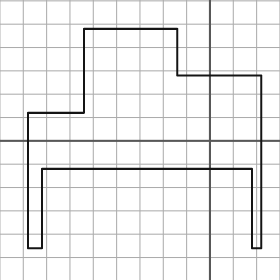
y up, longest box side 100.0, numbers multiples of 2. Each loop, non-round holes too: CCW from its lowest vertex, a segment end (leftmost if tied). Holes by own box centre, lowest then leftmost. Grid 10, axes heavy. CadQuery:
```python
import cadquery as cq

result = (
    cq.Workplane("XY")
    .moveTo(-78.0, -46.0)
    .lineTo(-72.0, -46.0)
    .lineTo(-72.0, -12.0)
    .lineTo(18.0, -12.0)
    .lineTo(18.0, -46.0)
    .lineTo(22.0, -46.0)
    .lineTo(22.0, 28.0)
    .lineTo(-14.0, 28.0)
    .lineTo(-14.0, 48.0)
    .lineTo(-54.0, 48.0)
    .lineTo(-54.0, 12.0)
    .lineTo(-78.0, 12.0)
    .close()
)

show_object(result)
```